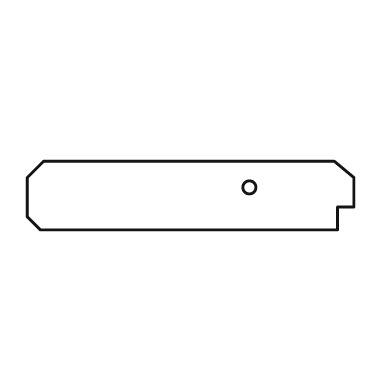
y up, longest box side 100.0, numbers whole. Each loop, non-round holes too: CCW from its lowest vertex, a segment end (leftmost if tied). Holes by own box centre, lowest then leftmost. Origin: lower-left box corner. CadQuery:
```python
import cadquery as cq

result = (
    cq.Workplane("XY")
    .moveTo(4.0, 0.0)
    .lineTo(95.0, 0.0)
    .lineTo(95.0, 7.0)
    .lineTo(100.0, 7.0)
    .lineTo(100.0, 16.0)
    .lineTo(94.0, 21.0)
    .lineTo(5.0, 21.0)
    .lineTo(0.0, 16.0)
    .lineTo(0.0, 4.0)
    .close()
    .moveTo(68.0, 13.0)
    .circle(2.0)
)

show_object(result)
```